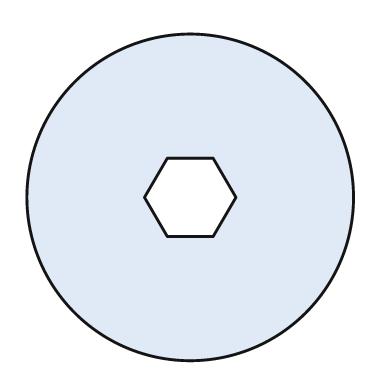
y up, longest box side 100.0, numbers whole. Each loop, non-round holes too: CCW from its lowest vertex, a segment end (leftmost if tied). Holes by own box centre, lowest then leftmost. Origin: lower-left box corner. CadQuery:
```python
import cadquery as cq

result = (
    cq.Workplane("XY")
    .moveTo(50.0, 50.0)
    .circle(50.0)
    .moveTo(43.0, 38.0)
    .lineTo(57.0, 38.0)
    .lineTo(64.0, 50.0)
    .lineTo(57.0, 62.0)
    .lineTo(43.0, 62.0)
    .lineTo(36.0, 50.0)
    .close()
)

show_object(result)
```